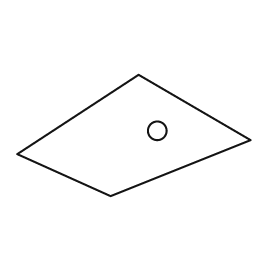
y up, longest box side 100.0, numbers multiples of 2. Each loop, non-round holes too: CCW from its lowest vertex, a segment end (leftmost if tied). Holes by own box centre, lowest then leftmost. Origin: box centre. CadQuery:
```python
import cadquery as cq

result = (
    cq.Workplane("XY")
    .moveTo(-10.0, -26.0)
    .lineTo(50.0, -2.0)
    .lineTo(2.0, 26.0)
    .lineTo(-50.0, -8.0)
    .close()
    .moveTo(10.0, 2.0)
    .circle(4.0)
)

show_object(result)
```